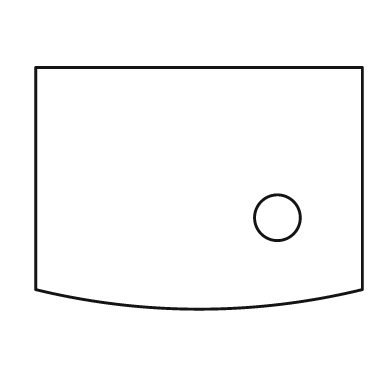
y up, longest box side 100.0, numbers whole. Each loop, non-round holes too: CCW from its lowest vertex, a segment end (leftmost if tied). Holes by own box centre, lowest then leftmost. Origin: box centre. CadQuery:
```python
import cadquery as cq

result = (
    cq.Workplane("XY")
    .moveTo(-50.0, -31.0)
    .threePointArc((0.0, -37.0), (50.0, -31.0))
    .lineTo(50.0, 37.0)
    .lineTo(-50.0, 37.0)
    .close()
    .moveTo(24.0, -9.0)
    .circle(7.0)
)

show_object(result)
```